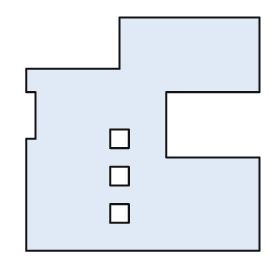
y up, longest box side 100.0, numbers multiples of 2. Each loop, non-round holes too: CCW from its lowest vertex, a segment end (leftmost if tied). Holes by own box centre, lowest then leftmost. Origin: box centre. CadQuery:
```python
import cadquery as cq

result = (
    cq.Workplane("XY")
    .moveTo(-50.0, -50.0)
    .lineTo(50.0, -50.0)
    .lineTo(50.0, -10.0)
    .lineTo(10.0, -10.0)
    .lineTo(10.0, 18.0)
    .lineTo(50.0, 18.0)
    .lineTo(50.0, 50.0)
    .lineTo(-10.0, 50.0)
    .lineTo(-10.0, 28.0)
    .lineTo(-50.0, 28.0)
    .lineTo(-50.0, 18.0)
    .lineTo(-46.0, 18.0)
    .lineTo(-46.0, -2.0)
    .lineTo(-50.0, -2.0)
    .close()
    .moveTo(-14.0, -38.0)
    .lineTo(-6.0, -38.0)
    .lineTo(-6.0, -30.0)
    .lineTo(-14.0, -30.0)
    .close()
    .moveTo(-14.0, -22.0)
    .lineTo(-6.0, -22.0)
    .lineTo(-6.0, -14.0)
    .lineTo(-14.0, -14.0)
    .close()
    .moveTo(-14.0, -6.0)
    .lineTo(-6.0, -6.0)
    .lineTo(-6.0, 2.0)
    .lineTo(-14.0, 2.0)
    .close()
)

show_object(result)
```